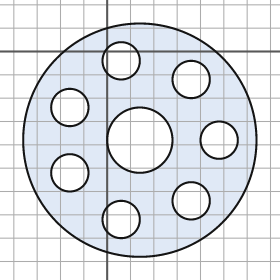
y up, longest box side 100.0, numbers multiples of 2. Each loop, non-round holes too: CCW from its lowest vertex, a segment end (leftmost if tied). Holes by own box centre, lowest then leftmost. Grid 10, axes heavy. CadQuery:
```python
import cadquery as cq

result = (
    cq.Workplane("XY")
    .moveTo(14.0, -38.0)
    .circle(50.0)
    .moveTo(6.0, -72.0)
    .circle(8.0)
    .moveTo(36.0, -64.0)
    .circle(8.0)
    .moveTo(-16.0, -52.0)
    .circle(8.0)
    .moveTo(14.0, -38.0)
    .circle(14.0)
    .moveTo(48.0, -38.0)
    .circle(8.0)
    .moveTo(-16.0, -24.0)
    .circle(8.0)
    .moveTo(36.0, -12.0)
    .circle(8.0)
    .moveTo(6.0, -4.0)
    .circle(8.0)
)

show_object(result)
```